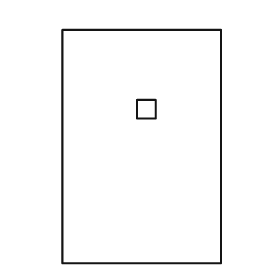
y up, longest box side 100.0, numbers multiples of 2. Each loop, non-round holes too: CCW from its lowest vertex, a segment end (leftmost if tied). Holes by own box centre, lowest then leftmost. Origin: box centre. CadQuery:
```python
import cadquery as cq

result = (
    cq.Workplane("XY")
    .moveTo(-34.0, -50.0)
    .lineTo(34.0, -50.0)
    .lineTo(34.0, 50.0)
    .lineTo(-34.0, 50.0)
    .close()
    .moveTo(-2.0, 12.0)
    .lineTo(6.0, 12.0)
    .lineTo(6.0, 20.0)
    .lineTo(-2.0, 20.0)
    .close()
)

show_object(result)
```